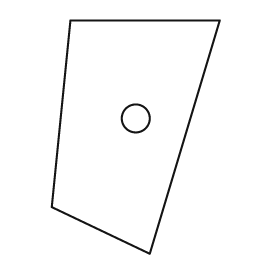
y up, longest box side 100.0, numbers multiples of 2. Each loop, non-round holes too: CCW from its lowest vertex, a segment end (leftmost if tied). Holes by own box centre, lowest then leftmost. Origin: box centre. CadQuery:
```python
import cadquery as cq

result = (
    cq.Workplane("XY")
    .moveTo(6.0, -50.0)
    .lineTo(36.0, 50.0)
    .lineTo(-28.0, 50.0)
    .lineTo(-36.0, -30.0)
    .close()
    .moveTo(0.0, 8.0)
    .circle(6.0)
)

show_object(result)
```